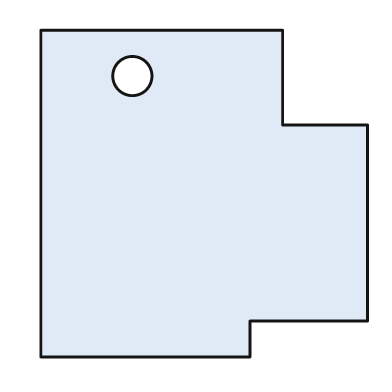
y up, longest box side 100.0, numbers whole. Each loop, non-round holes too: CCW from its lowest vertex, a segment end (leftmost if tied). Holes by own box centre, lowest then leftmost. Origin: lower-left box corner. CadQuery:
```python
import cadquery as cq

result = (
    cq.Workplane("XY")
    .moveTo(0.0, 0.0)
    .lineTo(64.0, 0.0)
    .lineTo(64.0, 11.0)
    .lineTo(100.0, 11.0)
    .lineTo(100.0, 71.0)
    .lineTo(74.0, 71.0)
    .lineTo(74.0, 100.0)
    .lineTo(0.0, 100.0)
    .close()
    .moveTo(28.0, 86.0)
    .circle(6.0)
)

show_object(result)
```